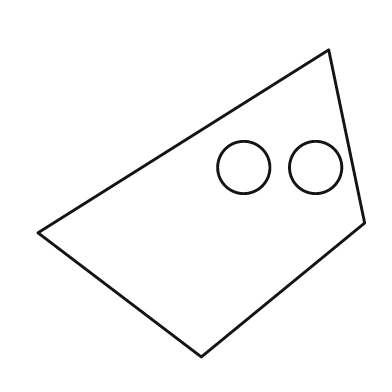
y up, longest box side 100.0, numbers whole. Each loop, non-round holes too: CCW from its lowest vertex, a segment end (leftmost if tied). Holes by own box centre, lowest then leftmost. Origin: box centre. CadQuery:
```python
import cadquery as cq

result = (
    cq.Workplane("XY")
    .moveTo(0.0, -47.0)
    .lineTo(50.0, -6.0)
    .lineTo(39.0, 47.0)
    .lineTo(-50.0, -9.0)
    .close()
    .moveTo(13.0, 11.0)
    .circle(8.0)
    .moveTo(35.0, 11.0)
    .circle(8.0)
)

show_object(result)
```